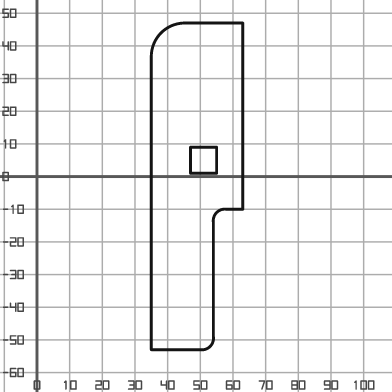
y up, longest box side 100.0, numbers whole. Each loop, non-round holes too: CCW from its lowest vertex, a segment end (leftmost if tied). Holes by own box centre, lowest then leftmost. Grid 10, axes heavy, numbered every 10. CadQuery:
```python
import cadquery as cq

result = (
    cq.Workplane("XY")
    .moveTo(35.0, -53.0)
    .lineTo(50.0, -53.0)
    .threePointArc((53.0, -52.0), (54.0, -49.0))
    .lineTo(54.0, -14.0)
    .threePointArc((55.0, -11.0), (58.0, -10.0))
    .lineTo(63.0, -10.0)
    .lineTo(63.0, 47.0)
    .lineTo(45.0, 47.0)
    .threePointArc((38.0, 44.0), (35.0, 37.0))
    .close()
    .moveTo(47.0, 1.0)
    .lineTo(55.0, 1.0)
    .lineTo(55.0, 9.0)
    .lineTo(47.0, 9.0)
    .close()
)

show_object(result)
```